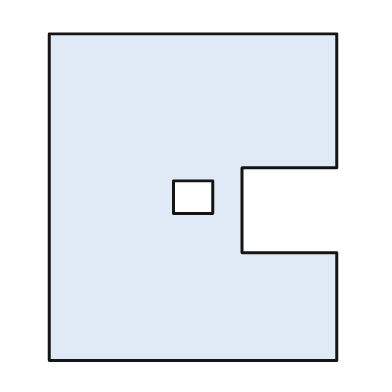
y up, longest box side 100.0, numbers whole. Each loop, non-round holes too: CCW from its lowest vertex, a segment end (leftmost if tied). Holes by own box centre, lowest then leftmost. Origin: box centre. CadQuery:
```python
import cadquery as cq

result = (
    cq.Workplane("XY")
    .moveTo(-44.0, -50.0)
    .lineTo(44.0, -50.0)
    .lineTo(44.0, -17.0)
    .lineTo(15.0, -17.0)
    .lineTo(15.0, 9.0)
    .lineTo(44.0, 9.0)
    .lineTo(44.0, 50.0)
    .lineTo(-44.0, 50.0)
    .close()
    .moveTo(-6.0, -5.0)
    .lineTo(6.0, -5.0)
    .lineTo(6.0, 5.0)
    .lineTo(-6.0, 5.0)
    .close()
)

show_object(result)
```